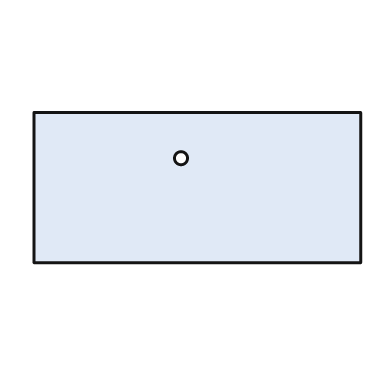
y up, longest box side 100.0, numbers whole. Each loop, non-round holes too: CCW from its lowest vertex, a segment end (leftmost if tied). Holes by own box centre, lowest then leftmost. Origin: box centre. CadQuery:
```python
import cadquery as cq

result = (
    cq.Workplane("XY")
    .moveTo(-50.0, -23.0)
    .lineTo(50.0, -23.0)
    .lineTo(50.0, 23.0)
    .lineTo(-50.0, 23.0)
    .close()
    .moveTo(-5.0, 9.0)
    .circle(2.0)
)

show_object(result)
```